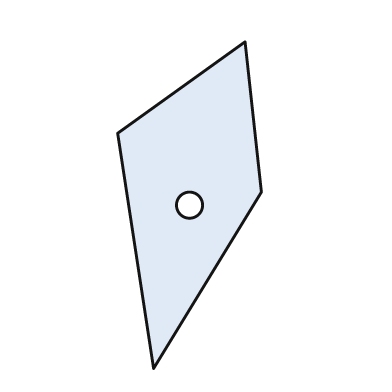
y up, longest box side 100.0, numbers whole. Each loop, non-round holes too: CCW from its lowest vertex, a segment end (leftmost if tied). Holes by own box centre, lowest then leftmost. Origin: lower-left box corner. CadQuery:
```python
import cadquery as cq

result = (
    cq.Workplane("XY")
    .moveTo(11.0, 0.0)
    .lineTo(44.0, 54.0)
    .lineTo(39.0, 100.0)
    .lineTo(0.0, 72.0)
    .close()
    .moveTo(22.0, 50.0)
    .circle(4.0)
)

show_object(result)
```